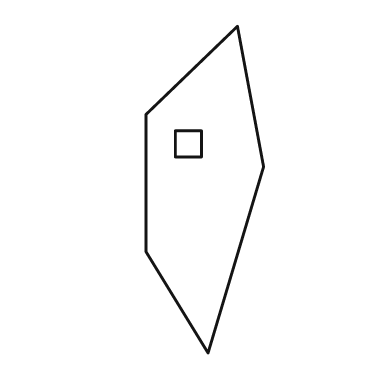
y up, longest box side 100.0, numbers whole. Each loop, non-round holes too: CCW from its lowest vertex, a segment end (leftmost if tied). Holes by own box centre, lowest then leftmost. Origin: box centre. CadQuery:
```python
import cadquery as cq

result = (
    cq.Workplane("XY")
    .moveTo(1.0, -50.0)
    .lineTo(18.0, 7.0)
    .lineTo(10.0, 50.0)
    .lineTo(-18.0, 23.0)
    .lineTo(-18.0, -19.0)
    .close()
    .moveTo(-9.0, 10.0)
    .lineTo(-1.0, 10.0)
    .lineTo(-1.0, 18.0)
    .lineTo(-9.0, 18.0)
    .close()
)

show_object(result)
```